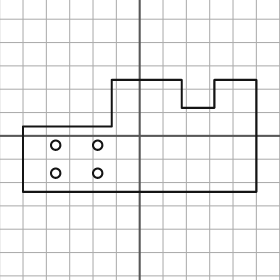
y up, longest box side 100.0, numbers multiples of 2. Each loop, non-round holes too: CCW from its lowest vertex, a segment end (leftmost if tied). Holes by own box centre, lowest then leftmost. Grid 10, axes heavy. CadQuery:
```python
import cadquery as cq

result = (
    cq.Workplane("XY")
    .moveTo(-50.0, -24.0)
    .lineTo(50.0, -24.0)
    .lineTo(50.0, 24.0)
    .lineTo(32.0, 24.0)
    .lineTo(32.0, 12.0)
    .lineTo(18.0, 12.0)
    .lineTo(18.0, 24.0)
    .lineTo(-12.0, 24.0)
    .lineTo(-12.0, 4.0)
    .lineTo(-50.0, 4.0)
    .close()
    .moveTo(-36.0, -16.0)
    .circle(2.0)
    .moveTo(-18.0, -16.0)
    .circle(2.0)
    .moveTo(-36.0, -4.0)
    .circle(2.0)
    .moveTo(-18.0, -4.0)
    .circle(2.0)
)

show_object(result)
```